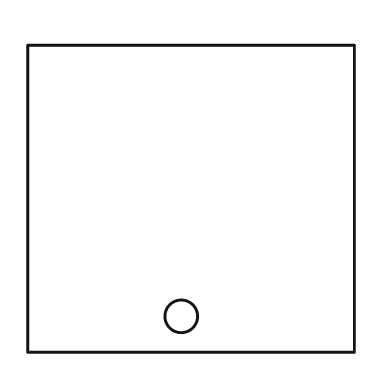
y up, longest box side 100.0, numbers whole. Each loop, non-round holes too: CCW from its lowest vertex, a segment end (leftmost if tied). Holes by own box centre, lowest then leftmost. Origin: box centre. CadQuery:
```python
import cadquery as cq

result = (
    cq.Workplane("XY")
    .moveTo(-50.0, -47.0)
    .lineTo(50.0, -47.0)
    .lineTo(50.0, 47.0)
    .lineTo(-50.0, 47.0)
    .close()
    .moveTo(-3.0, -36.0)
    .circle(5.0)
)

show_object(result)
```